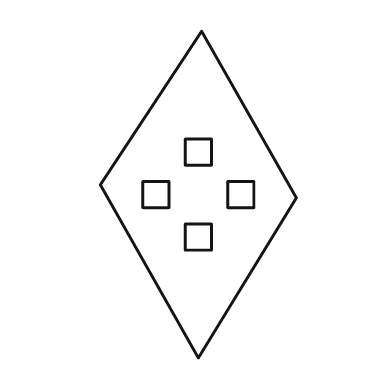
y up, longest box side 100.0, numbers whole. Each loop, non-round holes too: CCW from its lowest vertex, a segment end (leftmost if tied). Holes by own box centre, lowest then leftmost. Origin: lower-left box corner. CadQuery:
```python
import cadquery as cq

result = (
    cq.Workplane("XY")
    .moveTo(30.0, 0.0)
    .lineTo(60.0, 49.0)
    .lineTo(31.0, 100.0)
    .lineTo(0.0, 53.0)
    .close()
    .moveTo(26.0, 33.0)
    .lineTo(34.0, 33.0)
    .lineTo(34.0, 41.0)
    .lineTo(26.0, 41.0)
    .close()
    .moveTo(13.0, 46.0)
    .lineTo(21.0, 46.0)
    .lineTo(21.0, 54.0)
    .lineTo(13.0, 54.0)
    .close()
    .moveTo(39.0, 46.0)
    .lineTo(47.0, 46.0)
    .lineTo(47.0, 54.0)
    .lineTo(39.0, 54.0)
    .close()
    .moveTo(26.0, 59.0)
    .lineTo(34.0, 59.0)
    .lineTo(34.0, 67.0)
    .lineTo(26.0, 67.0)
    .close()
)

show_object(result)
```